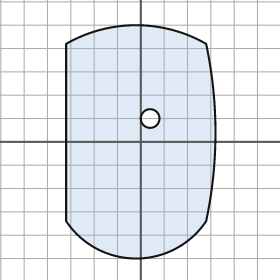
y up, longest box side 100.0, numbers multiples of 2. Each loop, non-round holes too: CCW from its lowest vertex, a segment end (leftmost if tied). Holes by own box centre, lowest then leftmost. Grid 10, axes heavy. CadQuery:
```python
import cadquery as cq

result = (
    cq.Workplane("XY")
    .moveTo(-32.0, -34.0)
    .threePointArc((-2.0, -50.0), (28.0, -34.0))
    .threePointArc((32.0, 4.0), (28.0, 42.0))
    .threePointArc((-2.0, 50.0), (-32.0, 42.0))
    .close()
    .moveTo(4.0, 10.0)
    .circle(4.0)
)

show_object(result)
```